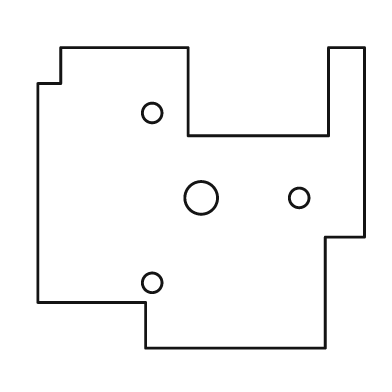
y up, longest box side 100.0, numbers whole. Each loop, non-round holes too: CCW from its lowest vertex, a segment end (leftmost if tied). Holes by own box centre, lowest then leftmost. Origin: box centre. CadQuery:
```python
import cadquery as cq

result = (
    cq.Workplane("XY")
    .moveTo(-17.0, -46.0)
    .lineTo(38.0, -46.0)
    .lineTo(38.0, -12.0)
    .lineTo(50.0, -12.0)
    .lineTo(50.0, 46.0)
    .lineTo(39.0, 46.0)
    .lineTo(39.0, 19.0)
    .lineTo(-4.0, 19.0)
    .lineTo(-4.0, 46.0)
    .lineTo(-43.0, 46.0)
    .lineTo(-43.0, 35.0)
    .lineTo(-50.0, 35.0)
    .lineTo(-50.0, -32.0)
    .lineTo(-17.0, -32.0)
    .close()
    .moveTo(-15.0, -26.0)
    .circle(3.0)
    .moveTo(0.0, 0.0)
    .circle(5.0)
    .moveTo(30.0, 0.0)
    .circle(3.0)
    .moveTo(-15.0, 26.0)
    .circle(3.0)
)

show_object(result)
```